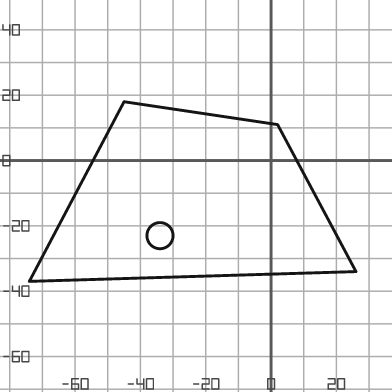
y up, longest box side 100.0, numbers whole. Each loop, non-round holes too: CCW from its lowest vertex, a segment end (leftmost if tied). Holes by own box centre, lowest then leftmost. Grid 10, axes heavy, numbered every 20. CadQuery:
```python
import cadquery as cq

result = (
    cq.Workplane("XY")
    .moveTo(-74.0, -37.0)
    .lineTo(26.0, -34.0)
    .lineTo(2.0, 11.0)
    .lineTo(-45.0, 18.0)
    .close()
    .moveTo(-34.0, -23.0)
    .circle(4.0)
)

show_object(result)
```